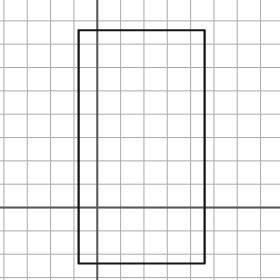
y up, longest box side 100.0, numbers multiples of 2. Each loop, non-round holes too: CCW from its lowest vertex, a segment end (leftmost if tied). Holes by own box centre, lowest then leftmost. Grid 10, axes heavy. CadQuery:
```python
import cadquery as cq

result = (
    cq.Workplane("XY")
    .moveTo(-8.0, -24.0)
    .lineTo(46.0, -24.0)
    .lineTo(46.0, 76.0)
    .lineTo(-8.0, 76.0)
    .close()
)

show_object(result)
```